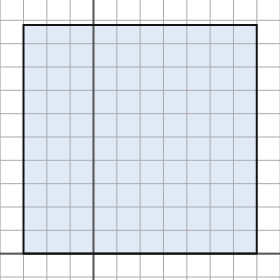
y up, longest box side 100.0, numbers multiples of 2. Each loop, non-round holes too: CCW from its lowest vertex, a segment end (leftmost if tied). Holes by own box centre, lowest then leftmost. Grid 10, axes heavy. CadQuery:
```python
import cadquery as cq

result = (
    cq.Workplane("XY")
    .moveTo(-30.0, 0.0)
    .lineTo(70.0, 0.0)
    .lineTo(70.0, 98.0)
    .lineTo(-30.0, 98.0)
    .close()
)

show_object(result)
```